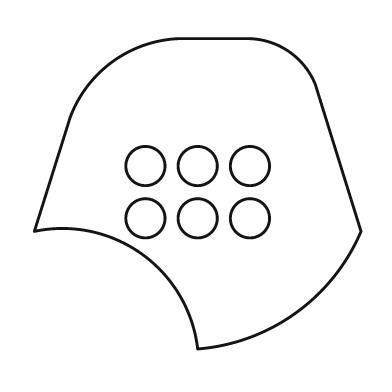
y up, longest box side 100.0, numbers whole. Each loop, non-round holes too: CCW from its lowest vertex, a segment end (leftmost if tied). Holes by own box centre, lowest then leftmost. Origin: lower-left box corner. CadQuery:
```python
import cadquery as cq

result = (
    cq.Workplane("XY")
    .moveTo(50.0, 0.0)
    .threePointArc((80.0, 11.0), (100.0, 36.0))
    .lineTo(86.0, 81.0)
    .threePointArc((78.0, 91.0), (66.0, 95.0))
    .lineTo(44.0, 95.0)
    .threePointArc((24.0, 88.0), (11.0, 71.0))
    .lineTo(0.0, 36.0)
    .threePointArc((33.0, 29.0), (50.0, 0.0))
    .close()
    .moveTo(34.0, 40.0)
    .circle(6.0)
    .moveTo(50.0, 40.0)
    .circle(6.0)
    .moveTo(66.0, 40.0)
    .circle(6.0)
    .moveTo(34.0, 56.0)
    .circle(6.0)
    .moveTo(50.0, 56.0)
    .circle(6.0)
    .moveTo(66.0, 56.0)
    .circle(6.0)
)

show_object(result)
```